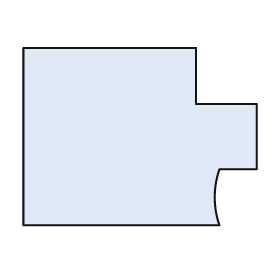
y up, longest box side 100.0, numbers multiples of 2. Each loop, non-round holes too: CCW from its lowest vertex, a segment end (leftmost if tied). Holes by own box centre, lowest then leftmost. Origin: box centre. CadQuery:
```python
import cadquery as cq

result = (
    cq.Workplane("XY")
    .moveTo(-50.0, -38.0)
    .lineTo(34.0, -38.0)
    .threePointArc((32.0, -26.0), (34.0, -14.0))
    .lineTo(50.0, -14.0)
    .lineTo(50.0, 14.0)
    .lineTo(24.0, 14.0)
    .lineTo(24.0, 38.0)
    .lineTo(-50.0, 38.0)
    .close()
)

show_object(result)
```